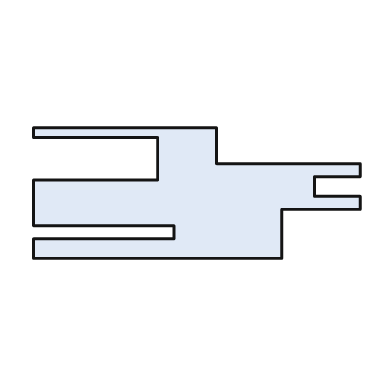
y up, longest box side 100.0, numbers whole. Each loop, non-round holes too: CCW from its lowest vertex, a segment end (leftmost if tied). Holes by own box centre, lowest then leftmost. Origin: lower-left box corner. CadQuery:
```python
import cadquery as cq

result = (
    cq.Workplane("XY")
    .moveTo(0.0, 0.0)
    .lineTo(76.0, 0.0)
    .lineTo(76.0, 15.0)
    .lineTo(100.0, 15.0)
    .lineTo(100.0, 19.0)
    .lineTo(86.0, 19.0)
    .lineTo(86.0, 25.0)
    .lineTo(100.0, 25.0)
    .lineTo(100.0, 29.0)
    .lineTo(56.0, 29.0)
    .lineTo(56.0, 40.0)
    .lineTo(0.0, 40.0)
    .lineTo(0.0, 37.0)
    .lineTo(38.0, 37.0)
    .lineTo(38.0, 24.0)
    .lineTo(0.0, 24.0)
    .lineTo(0.0, 10.0)
    .lineTo(43.0, 10.0)
    .lineTo(43.0, 6.0)
    .lineTo(0.0, 6.0)
    .close()
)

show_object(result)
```